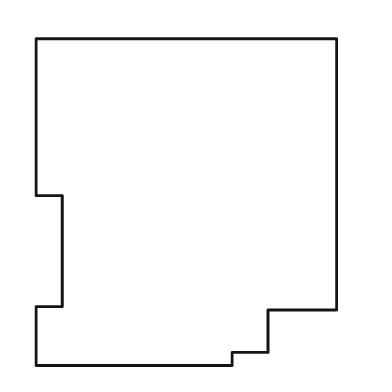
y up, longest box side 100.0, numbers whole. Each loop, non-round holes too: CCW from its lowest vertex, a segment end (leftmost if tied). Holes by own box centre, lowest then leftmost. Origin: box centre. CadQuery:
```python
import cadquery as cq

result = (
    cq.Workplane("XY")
    .moveTo(-46.0, -50.0)
    .lineTo(14.0, -50.0)
    .lineTo(14.0, -46.0)
    .lineTo(25.0, -46.0)
    .lineTo(25.0, -33.0)
    .lineTo(46.0, -33.0)
    .lineTo(46.0, 50.0)
    .lineTo(-46.0, 50.0)
    .lineTo(-46.0, 2.0)
    .lineTo(-38.0, 2.0)
    .lineTo(-38.0, -32.0)
    .lineTo(-46.0, -32.0)
    .close()
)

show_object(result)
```